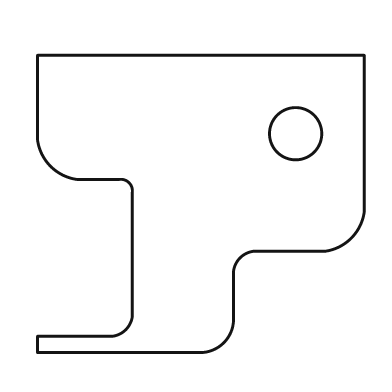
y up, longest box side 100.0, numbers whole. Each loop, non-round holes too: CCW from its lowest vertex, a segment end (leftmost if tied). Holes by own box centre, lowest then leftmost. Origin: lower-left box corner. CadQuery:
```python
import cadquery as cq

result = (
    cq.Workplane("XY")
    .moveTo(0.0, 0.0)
    .lineTo(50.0, 0.0)
    .threePointArc((57.0, 3.0), (60.0, 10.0))
    .lineTo(60.0, 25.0)
    .threePointArc((62.0, 29.0), (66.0, 31.0))
    .lineTo(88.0, 31.0)
    .threePointArc((96.0, 35.0), (100.0, 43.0))
    .lineTo(100.0, 91.0)
    .lineTo(0.0, 91.0)
    .lineTo(0.0, 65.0)
    .threePointArc((4.0, 57.0), (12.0, 53.0))
    .lineTo(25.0, 53.0)
    .threePointArc((28.0, 52.0), (29.0, 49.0))
    .lineTo(29.0, 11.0)
    .threePointArc((27.0, 7.0), (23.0, 5.0))
    .lineTo(0.0, 5.0)
    .close()
    .moveTo(79.0, 67.0)
    .circle(8.0)
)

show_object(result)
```